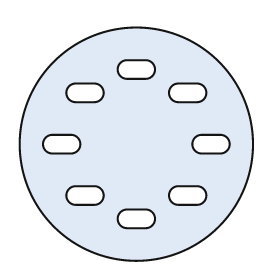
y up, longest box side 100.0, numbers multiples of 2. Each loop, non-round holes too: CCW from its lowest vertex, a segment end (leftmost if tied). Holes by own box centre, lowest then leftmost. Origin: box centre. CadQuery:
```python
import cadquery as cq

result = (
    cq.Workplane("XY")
    .moveTo(0.0, 0.0)
    .circle(50.0)
    .moveTo(-4.0, -36.0)
    .lineTo(4.0, -36.0)
    .threePointArc((8.0, -32.0), (4.0, -28.0))
    .lineTo(-4.0, -28.0)
    .threePointArc((-8.0, -32.0), (-4.0, -36.0))
    .close()
    .moveTo(-26.0, -26.0)
    .lineTo(-18.0, -26.0)
    .threePointArc((-14.0, -22.0), (-18.0, -18.0))
    .lineTo(-26.0, -18.0)
    .threePointArc((-30.0, -22.0), (-26.0, -26.0))
    .close()
    .moveTo(18.0, -26.0)
    .lineTo(26.0, -26.0)
    .threePointArc((30.0, -22.0), (26.0, -18.0))
    .lineTo(18.0, -18.0)
    .threePointArc((14.0, -22.0), (18.0, -26.0))
    .close()
    .moveTo(-36.0, -4.0)
    .lineTo(-28.0, -4.0)
    .threePointArc((-24.0, 0.0), (-28.0, 4.0))
    .lineTo(-36.0, 4.0)
    .threePointArc((-40.0, 0.0), (-36.0, -4.0))
    .close()
    .moveTo(28.0, -4.0)
    .lineTo(36.0, -4.0)
    .threePointArc((40.0, 0.0), (36.0, 4.0))
    .lineTo(28.0, 4.0)
    .threePointArc((24.0, 0.0), (28.0, -4.0))
    .close()
    .moveTo(-26.0, 18.0)
    .lineTo(-18.0, 18.0)
    .threePointArc((-14.0, 22.0), (-18.0, 26.0))
    .lineTo(-26.0, 26.0)
    .threePointArc((-30.0, 22.0), (-26.0, 18.0))
    .close()
    .moveTo(18.0, 18.0)
    .lineTo(26.0, 18.0)
    .threePointArc((30.0, 22.0), (26.0, 26.0))
    .lineTo(18.0, 26.0)
    .threePointArc((14.0, 22.0), (18.0, 18.0))
    .close()
    .moveTo(-4.0, 28.0)
    .lineTo(4.0, 28.0)
    .threePointArc((8.0, 32.0), (4.0, 36.0))
    .lineTo(-4.0, 36.0)
    .threePointArc((-8.0, 32.0), (-4.0, 28.0))
    .close()
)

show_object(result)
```